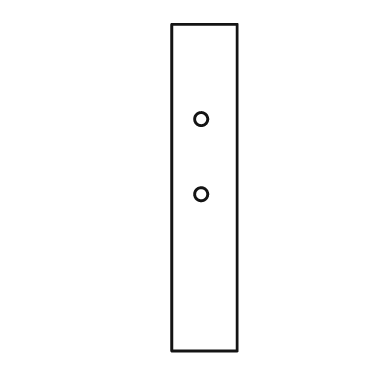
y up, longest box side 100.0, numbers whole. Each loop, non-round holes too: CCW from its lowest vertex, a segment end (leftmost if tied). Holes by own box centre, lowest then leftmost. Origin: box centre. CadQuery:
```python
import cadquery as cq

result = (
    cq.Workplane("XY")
    .moveTo(-10.0, -50.0)
    .lineTo(10.0, -50.0)
    .lineTo(10.0, 50.0)
    .lineTo(-10.0, 50.0)
    .close()
    .moveTo(-1.0, -2.0)
    .circle(2.0)
    .moveTo(-1.0, 21.0)
    .circle(2.0)
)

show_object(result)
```